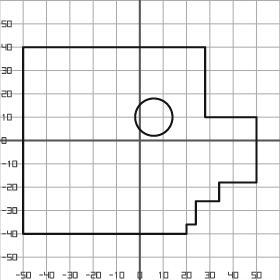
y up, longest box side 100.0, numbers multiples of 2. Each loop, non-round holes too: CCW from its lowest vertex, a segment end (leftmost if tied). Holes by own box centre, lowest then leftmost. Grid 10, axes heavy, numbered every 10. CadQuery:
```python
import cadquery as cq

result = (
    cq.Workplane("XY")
    .moveTo(-50.0, -40.0)
    .lineTo(20.0, -40.0)
    .lineTo(20.0, -36.0)
    .lineTo(24.0, -36.0)
    .lineTo(24.0, -26.0)
    .lineTo(34.0, -26.0)
    .lineTo(34.0, -18.0)
    .lineTo(50.0, -18.0)
    .lineTo(50.0, 10.0)
    .lineTo(28.0, 10.0)
    .lineTo(28.0, 40.0)
    .lineTo(-50.0, 40.0)
    .close()
    .moveTo(6.0, 10.0)
    .circle(8.0)
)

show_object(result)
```